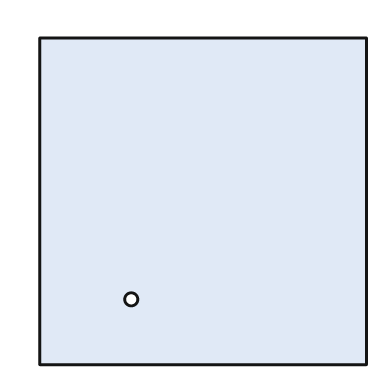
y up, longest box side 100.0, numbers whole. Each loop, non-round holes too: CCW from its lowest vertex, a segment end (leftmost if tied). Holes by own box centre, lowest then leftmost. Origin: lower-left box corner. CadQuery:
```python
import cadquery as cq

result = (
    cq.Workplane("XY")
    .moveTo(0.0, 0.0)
    .lineTo(100.0, 0.0)
    .lineTo(100.0, 100.0)
    .lineTo(0.0, 100.0)
    .close()
    .moveTo(28.0, 20.0)
    .circle(2.0)
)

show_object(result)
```